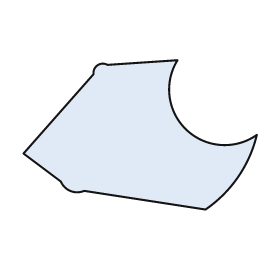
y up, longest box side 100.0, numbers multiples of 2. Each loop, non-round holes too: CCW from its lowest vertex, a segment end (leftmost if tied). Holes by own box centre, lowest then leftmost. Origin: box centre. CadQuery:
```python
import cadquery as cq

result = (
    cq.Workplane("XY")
    .moveTo(28.0, -32.0)
    .threePointArc((42.0, -18.0), (50.0, 0.0))
    .threePointArc((20.0, 2.0), (16.0, 32.0))
    .lineTo(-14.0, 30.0)
    .threePointArc((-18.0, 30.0), (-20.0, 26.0))
    .lineTo(-50.0, -8.0)
    .lineTo(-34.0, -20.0)
    .threePointArc((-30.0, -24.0), (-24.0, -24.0))
    .close()
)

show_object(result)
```